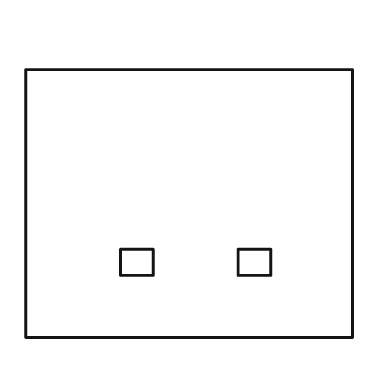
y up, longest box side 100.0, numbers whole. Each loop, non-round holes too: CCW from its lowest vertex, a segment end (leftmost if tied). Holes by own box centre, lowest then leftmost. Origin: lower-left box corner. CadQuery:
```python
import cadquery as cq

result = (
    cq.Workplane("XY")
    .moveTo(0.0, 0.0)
    .lineTo(100.0, 0.0)
    .lineTo(100.0, 82.0)
    .lineTo(0.0, 82.0)
    .close()
    .moveTo(29.0, 19.0)
    .lineTo(39.0, 19.0)
    .lineTo(39.0, 27.0)
    .lineTo(29.0, 27.0)
    .close()
    .moveTo(65.0, 19.0)
    .lineTo(75.0, 19.0)
    .lineTo(75.0, 27.0)
    .lineTo(65.0, 27.0)
    .close()
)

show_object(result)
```